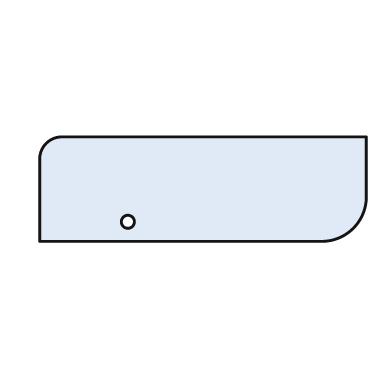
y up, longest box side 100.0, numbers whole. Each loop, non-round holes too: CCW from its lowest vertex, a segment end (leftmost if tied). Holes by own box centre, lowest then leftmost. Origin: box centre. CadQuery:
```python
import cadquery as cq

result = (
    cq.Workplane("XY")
    .moveTo(-50.0, -16.0)
    .lineTo(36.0, -16.0)
    .threePointArc((46.0, -12.0), (50.0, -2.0))
    .lineTo(50.0, 16.0)
    .lineTo(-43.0, 16.0)
    .threePointArc((-48.0, 14.0), (-50.0, 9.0))
    .close()
    .moveTo(-23.0, -10.0)
    .circle(2.0)
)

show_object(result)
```